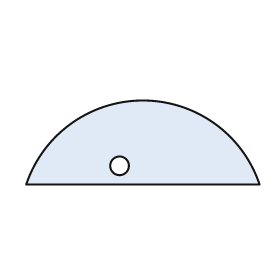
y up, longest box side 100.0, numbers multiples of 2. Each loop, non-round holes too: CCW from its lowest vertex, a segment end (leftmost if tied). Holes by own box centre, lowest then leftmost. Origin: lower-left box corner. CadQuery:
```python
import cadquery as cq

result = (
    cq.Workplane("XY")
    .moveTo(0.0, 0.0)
    .lineTo(100.0, 0.0)
    .threePointArc((50.0, 36.0), (0.0, 0.0))
    .close()
    .moveTo(40.0, 8.0)
    .circle(4.0)
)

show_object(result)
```